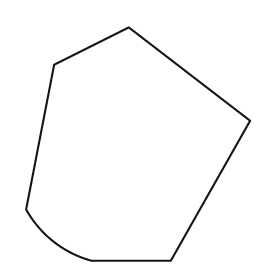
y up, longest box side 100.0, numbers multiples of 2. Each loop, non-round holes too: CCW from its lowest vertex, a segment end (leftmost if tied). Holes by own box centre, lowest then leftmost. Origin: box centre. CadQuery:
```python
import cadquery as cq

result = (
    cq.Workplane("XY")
    .moveTo(-20.0, -50.0)
    .lineTo(14.0, -50.0)
    .lineTo(48.0, 10.0)
    .lineTo(-4.0, 50.0)
    .lineTo(-36.0, 34.0)
    .lineTo(-48.0, -28.0)
    .threePointArc((-36.0, -42.0), (-20.0, -50.0))
    .close()
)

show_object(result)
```